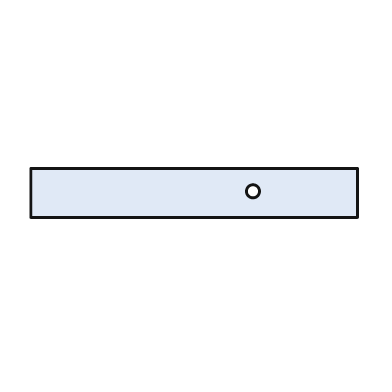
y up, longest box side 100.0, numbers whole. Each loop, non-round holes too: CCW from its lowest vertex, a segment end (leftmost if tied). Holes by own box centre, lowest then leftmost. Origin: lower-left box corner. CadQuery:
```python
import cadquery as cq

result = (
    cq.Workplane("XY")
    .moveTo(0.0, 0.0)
    .lineTo(100.0, 0.0)
    .lineTo(100.0, 15.0)
    .lineTo(0.0, 15.0)
    .close()
    .moveTo(68.0, 8.0)
    .circle(2.0)
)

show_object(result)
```